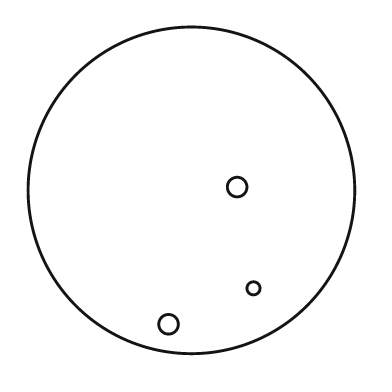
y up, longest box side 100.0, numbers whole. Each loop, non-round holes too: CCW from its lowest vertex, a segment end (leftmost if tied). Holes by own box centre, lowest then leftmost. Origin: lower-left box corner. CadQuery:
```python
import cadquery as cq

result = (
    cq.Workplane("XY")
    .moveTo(50.0, 50.0)
    .circle(50.0)
    .moveTo(43.0, 9.0)
    .circle(3.0)
    .moveTo(69.0, 20.0)
    .circle(2.0)
    .moveTo(64.0, 51.0)
    .circle(3.0)
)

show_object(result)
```